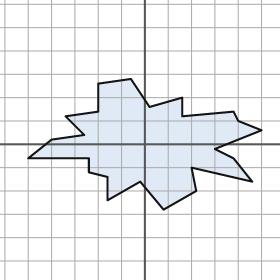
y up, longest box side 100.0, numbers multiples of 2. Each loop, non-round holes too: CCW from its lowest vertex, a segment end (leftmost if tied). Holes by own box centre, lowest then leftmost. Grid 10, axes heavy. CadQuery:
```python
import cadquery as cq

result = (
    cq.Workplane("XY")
    .moveTo(8.0, -28.0)
    .lineTo(22.0, -20.0)
    .lineTo(20.0, -10.0)
    .lineTo(46.0, -16.0)
    .lineTo(38.0, -6.0)
    .lineTo(30.0, -2.0)
    .lineTo(50.0, 6.0)
    .lineTo(40.0, 10.0)
    .lineTo(38.0, 14.0)
    .lineTo(16.0, 12.0)
    .lineTo(16.0, 20.0)
    .lineTo(2.0, 16.0)
    .lineTo(-6.0, 28.0)
    .lineTo(-20.0, 26.0)
    .lineTo(-20.0, 14.0)
    .lineTo(-34.0, 12.0)
    .lineTo(-26.0, 4.0)
    .lineTo(-40.0, 2.0)
    .lineTo(-50.0, -6.0)
    .lineTo(-24.0, -6.0)
    .lineTo(-24.0, -12.0)
    .lineTo(-16.0, -14.0)
    .lineTo(-16.0, -24.0)
    .lineTo(-2.0, -16.0)
    .close()
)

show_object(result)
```